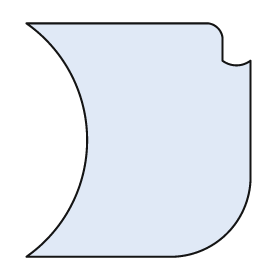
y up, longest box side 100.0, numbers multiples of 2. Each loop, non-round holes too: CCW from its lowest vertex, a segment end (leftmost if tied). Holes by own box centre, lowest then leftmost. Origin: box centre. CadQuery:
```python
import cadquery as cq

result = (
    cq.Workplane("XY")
    .moveTo(-48.0, -50.0)
    .lineTo(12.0, -50.0)
    .threePointArc((38.0, -40.0), (48.0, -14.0))
    .lineTo(48.0, 34.0)
    .threePointArc((42.0, 32.0), (36.0, 34.0))
    .lineTo(36.0, 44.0)
    .threePointArc((34.0, 48.0), (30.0, 50.0))
    .lineTo(-48.0, 50.0)
    .threePointArc((-22.0, 0.0), (-48.0, -50.0))
    .close()
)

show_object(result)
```